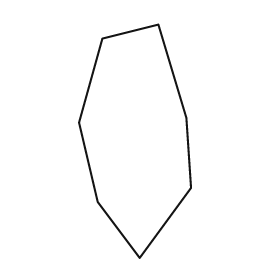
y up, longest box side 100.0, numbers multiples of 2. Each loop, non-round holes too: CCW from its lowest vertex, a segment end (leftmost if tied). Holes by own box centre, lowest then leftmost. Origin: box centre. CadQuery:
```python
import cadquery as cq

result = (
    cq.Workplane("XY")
    .moveTo(2.0, -50.0)
    .lineTo(24.0, -20.0)
    .lineTo(22.0, 10.0)
    .lineTo(10.0, 50.0)
    .lineTo(-14.0, 44.0)
    .lineTo(-24.0, 8.0)
    .lineTo(-16.0, -26.0)
    .close()
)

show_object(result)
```